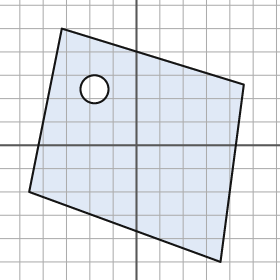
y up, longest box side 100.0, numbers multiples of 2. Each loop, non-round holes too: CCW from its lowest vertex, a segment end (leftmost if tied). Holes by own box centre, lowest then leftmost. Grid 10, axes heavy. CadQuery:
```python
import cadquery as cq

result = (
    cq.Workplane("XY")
    .moveTo(36.0, -50.0)
    .lineTo(46.0, 26.0)
    .lineTo(-32.0, 50.0)
    .lineTo(-46.0, -20.0)
    .close()
    .moveTo(-18.0, 24.0)
    .circle(6.0)
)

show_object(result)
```